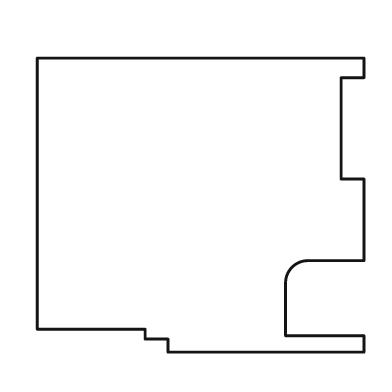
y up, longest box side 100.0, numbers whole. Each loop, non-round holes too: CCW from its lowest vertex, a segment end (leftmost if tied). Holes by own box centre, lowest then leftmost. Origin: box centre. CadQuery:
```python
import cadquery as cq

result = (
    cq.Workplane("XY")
    .moveTo(-10.0, -45.0)
    .lineTo(50.0, -45.0)
    .lineTo(50.0, -40.0)
    .lineTo(26.0, -40.0)
    .lineTo(26.0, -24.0)
    .threePointArc((28.0, -19.0), (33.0, -17.0))
    .lineTo(50.0, -17.0)
    .lineTo(50.0, 8.0)
    .lineTo(43.0, 8.0)
    .lineTo(43.0, 39.0)
    .lineTo(50.0, 39.0)
    .lineTo(50.0, 45.0)
    .lineTo(-50.0, 45.0)
    .lineTo(-50.0, -38.0)
    .lineTo(-17.0, -38.0)
    .lineTo(-17.0, -41.0)
    .lineTo(-10.0, -41.0)
    .close()
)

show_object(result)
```